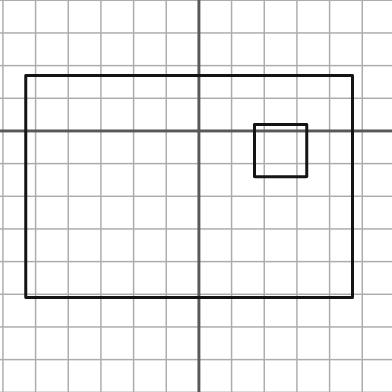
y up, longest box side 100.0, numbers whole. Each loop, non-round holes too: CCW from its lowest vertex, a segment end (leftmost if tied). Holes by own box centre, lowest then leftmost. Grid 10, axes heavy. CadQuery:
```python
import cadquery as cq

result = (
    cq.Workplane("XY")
    .moveTo(-53.0, -51.0)
    .lineTo(47.0, -51.0)
    .lineTo(47.0, 17.0)
    .lineTo(-53.0, 17.0)
    .close()
    .moveTo(17.0, -14.0)
    .lineTo(33.0, -14.0)
    .lineTo(33.0, 2.0)
    .lineTo(17.0, 2.0)
    .close()
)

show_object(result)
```